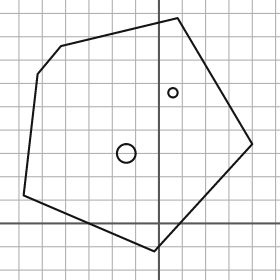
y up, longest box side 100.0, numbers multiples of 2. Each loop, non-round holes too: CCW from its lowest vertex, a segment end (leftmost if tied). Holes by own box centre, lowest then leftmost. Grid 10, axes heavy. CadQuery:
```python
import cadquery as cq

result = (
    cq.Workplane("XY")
    .moveTo(-2.0, -12.0)
    .lineTo(40.0, 34.0)
    .lineTo(8.0, 88.0)
    .lineTo(-42.0, 76.0)
    .lineTo(-52.0, 64.0)
    .lineTo(-58.0, 12.0)
    .close()
    .moveTo(-14.0, 30.0)
    .circle(4.0)
    .moveTo(6.0, 56.0)
    .circle(2.0)
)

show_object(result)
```